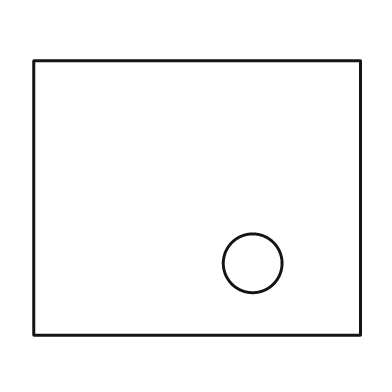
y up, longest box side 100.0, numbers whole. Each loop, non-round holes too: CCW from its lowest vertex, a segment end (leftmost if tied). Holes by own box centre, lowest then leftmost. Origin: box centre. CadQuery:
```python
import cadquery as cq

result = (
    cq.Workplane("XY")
    .moveTo(-50.0, -42.0)
    .lineTo(50.0, -42.0)
    .lineTo(50.0, 42.0)
    .lineTo(-50.0, 42.0)
    .close()
    .moveTo(17.0, -20.0)
    .circle(9.0)
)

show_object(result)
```